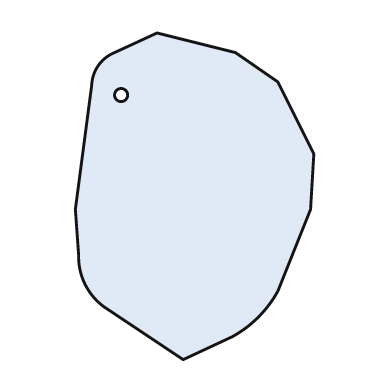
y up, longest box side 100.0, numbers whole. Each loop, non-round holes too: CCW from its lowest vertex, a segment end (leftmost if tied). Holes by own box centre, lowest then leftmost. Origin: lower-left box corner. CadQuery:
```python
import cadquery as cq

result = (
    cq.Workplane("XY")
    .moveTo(33.0, 0.0)
    .lineTo(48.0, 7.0)
    .threePointArc((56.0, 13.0), (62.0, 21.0))
    .lineTo(72.0, 46.0)
    .lineTo(73.0, 63.0)
    .lineTo(62.0, 85.0)
    .lineTo(49.0, 94.0)
    .lineTo(25.0, 100.0)
    .lineTo(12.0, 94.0)
    .threePointArc((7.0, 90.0), (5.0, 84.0))
    .lineTo(0.0, 46.0)
    .lineTo(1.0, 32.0)
    .threePointArc((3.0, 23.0), (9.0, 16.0))
    .close()
    .moveTo(14.0, 81.0)
    .circle(2.0)
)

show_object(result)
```